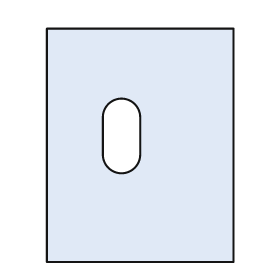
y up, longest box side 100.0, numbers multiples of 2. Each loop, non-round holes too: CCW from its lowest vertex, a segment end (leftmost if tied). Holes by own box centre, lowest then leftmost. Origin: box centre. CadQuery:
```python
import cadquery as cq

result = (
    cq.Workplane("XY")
    .moveTo(-40.0, -50.0)
    .lineTo(40.0, -50.0)
    .lineTo(40.0, 50.0)
    .lineTo(-40.0, 50.0)
    .close()
    .moveTo(-16.0, -4.0)
    .threePointArc((-8.0, -12.0), (0.0, -4.0))
    .lineTo(0.0, 12.0)
    .threePointArc((-8.0, 20.0), (-16.0, 12.0))
    .close()
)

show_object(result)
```